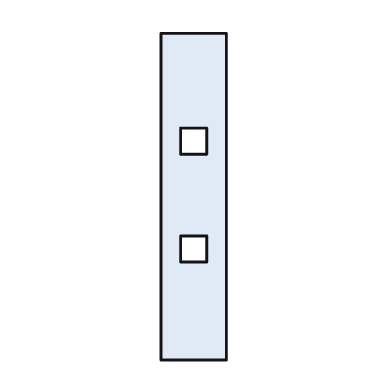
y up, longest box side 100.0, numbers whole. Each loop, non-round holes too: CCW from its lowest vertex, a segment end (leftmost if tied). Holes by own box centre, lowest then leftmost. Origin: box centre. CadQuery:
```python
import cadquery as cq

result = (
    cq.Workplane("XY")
    .moveTo(-10.0, -50.0)
    .lineTo(10.0, -50.0)
    .lineTo(10.0, 50.0)
    .lineTo(-10.0, 50.0)
    .close()
    .moveTo(-4.0, -20.0)
    .lineTo(4.0, -20.0)
    .lineTo(4.0, -12.0)
    .lineTo(-4.0, -12.0)
    .close()
    .moveTo(-4.0, 13.0)
    .lineTo(4.0, 13.0)
    .lineTo(4.0, 21.0)
    .lineTo(-4.0, 21.0)
    .close()
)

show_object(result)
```